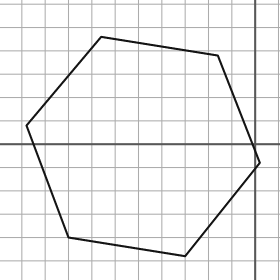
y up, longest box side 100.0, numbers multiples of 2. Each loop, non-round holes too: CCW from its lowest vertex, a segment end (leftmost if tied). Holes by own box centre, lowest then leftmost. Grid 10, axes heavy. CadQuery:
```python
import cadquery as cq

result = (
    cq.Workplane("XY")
    .moveTo(-30.0, -48.0)
    .lineTo(2.0, -8.0)
    .lineTo(-16.0, 38.0)
    .lineTo(-66.0, 46.0)
    .lineTo(-98.0, 8.0)
    .lineTo(-80.0, -40.0)
    .close()
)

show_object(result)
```